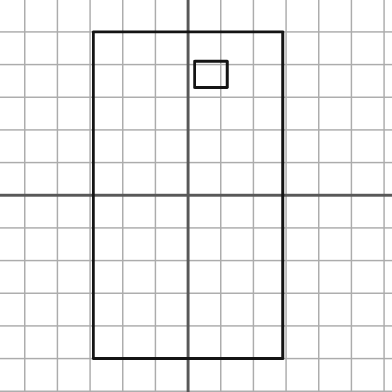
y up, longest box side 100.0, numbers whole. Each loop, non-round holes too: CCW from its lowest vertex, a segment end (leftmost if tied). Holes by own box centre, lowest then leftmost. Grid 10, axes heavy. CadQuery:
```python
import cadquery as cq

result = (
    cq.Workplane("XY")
    .moveTo(-29.0, -50.0)
    .lineTo(29.0, -50.0)
    .lineTo(29.0, 50.0)
    .lineTo(-29.0, 50.0)
    .close()
    .moveTo(2.0, 33.0)
    .lineTo(12.0, 33.0)
    .lineTo(12.0, 41.0)
    .lineTo(2.0, 41.0)
    .close()
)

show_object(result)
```